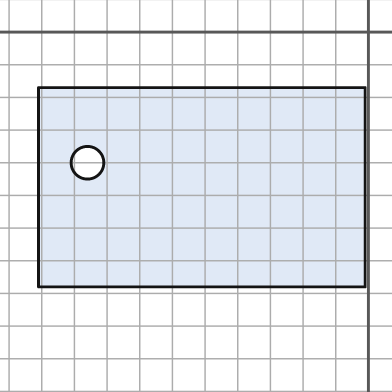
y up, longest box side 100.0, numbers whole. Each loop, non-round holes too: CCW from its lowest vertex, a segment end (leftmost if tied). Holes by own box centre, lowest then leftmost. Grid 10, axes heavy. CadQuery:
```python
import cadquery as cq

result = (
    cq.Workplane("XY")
    .moveTo(-101.0, -78.0)
    .lineTo(-1.0, -78.0)
    .lineTo(-1.0, -17.0)
    .lineTo(-101.0, -17.0)
    .close()
    .moveTo(-86.0, -40.0)
    .circle(5.0)
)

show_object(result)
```